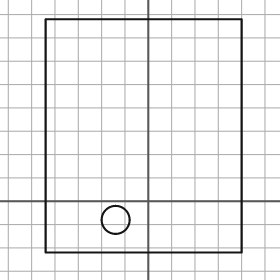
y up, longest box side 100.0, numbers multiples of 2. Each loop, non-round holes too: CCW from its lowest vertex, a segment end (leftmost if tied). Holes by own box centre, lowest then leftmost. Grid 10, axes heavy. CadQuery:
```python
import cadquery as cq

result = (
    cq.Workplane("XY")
    .moveTo(-44.0, -22.0)
    .lineTo(40.0, -22.0)
    .lineTo(40.0, 78.0)
    .lineTo(-44.0, 78.0)
    .close()
    .moveTo(-14.0, -8.0)
    .circle(6.0)
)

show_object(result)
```